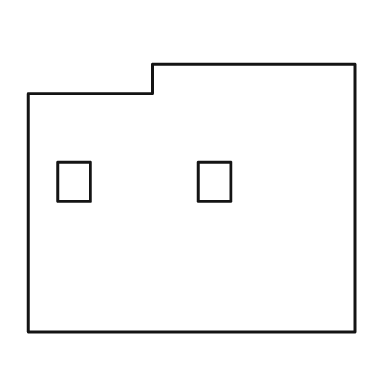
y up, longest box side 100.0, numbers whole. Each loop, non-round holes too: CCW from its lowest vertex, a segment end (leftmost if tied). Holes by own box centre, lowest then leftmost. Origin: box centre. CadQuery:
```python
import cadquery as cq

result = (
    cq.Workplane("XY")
    .moveTo(-50.0, -41.0)
    .lineTo(50.0, -41.0)
    .lineTo(50.0, 41.0)
    .lineTo(-12.0, 41.0)
    .lineTo(-12.0, 32.0)
    .lineTo(-50.0, 32.0)
    .close()
    .moveTo(-41.0, -1.0)
    .lineTo(-31.0, -1.0)
    .lineTo(-31.0, 11.0)
    .lineTo(-41.0, 11.0)
    .close()
    .moveTo(2.0, -1.0)
    .lineTo(12.0, -1.0)
    .lineTo(12.0, 11.0)
    .lineTo(2.0, 11.0)
    .close()
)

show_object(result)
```